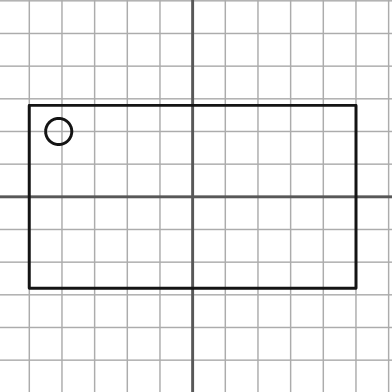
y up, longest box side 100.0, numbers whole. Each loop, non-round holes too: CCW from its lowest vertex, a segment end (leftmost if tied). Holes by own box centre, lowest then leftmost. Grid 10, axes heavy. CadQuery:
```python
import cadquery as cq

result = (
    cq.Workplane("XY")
    .moveTo(-50.0, -28.0)
    .lineTo(50.0, -28.0)
    .lineTo(50.0, 28.0)
    .lineTo(-50.0, 28.0)
    .close()
    .moveTo(-41.0, 20.0)
    .circle(4.0)
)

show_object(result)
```